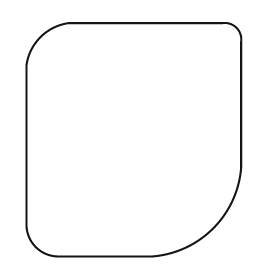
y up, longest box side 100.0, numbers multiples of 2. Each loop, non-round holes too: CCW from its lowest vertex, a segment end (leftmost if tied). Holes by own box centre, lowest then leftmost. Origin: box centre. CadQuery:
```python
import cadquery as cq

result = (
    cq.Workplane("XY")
    .moveTo(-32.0, -50.0)
    .lineTo(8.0, -50.0)
    .threePointArc((34.0, -38.0), (46.0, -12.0))
    .lineTo(46.0, 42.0)
    .threePointArc((44.0, 48.0), (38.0, 50.0))
    .lineTo(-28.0, 50.0)
    .threePointArc((-40.0, 44.0), (-46.0, 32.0))
    .lineTo(-46.0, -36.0)
    .threePointArc((-42.0, -46.0), (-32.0, -50.0))
    .close()
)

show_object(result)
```